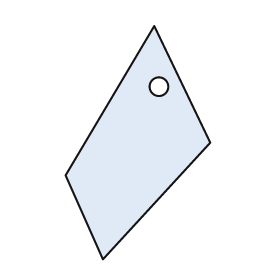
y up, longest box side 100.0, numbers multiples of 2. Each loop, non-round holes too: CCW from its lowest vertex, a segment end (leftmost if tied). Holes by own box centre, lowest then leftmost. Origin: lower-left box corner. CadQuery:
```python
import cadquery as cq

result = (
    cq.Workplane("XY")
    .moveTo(16.0, 0.0)
    .lineTo(62.0, 50.0)
    .lineTo(38.0, 100.0)
    .lineTo(0.0, 36.0)
    .close()
    .moveTo(40.0, 74.0)
    .circle(4.0)
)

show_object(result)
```